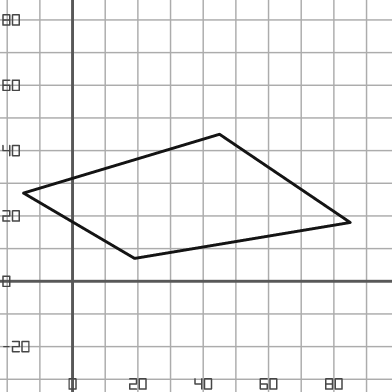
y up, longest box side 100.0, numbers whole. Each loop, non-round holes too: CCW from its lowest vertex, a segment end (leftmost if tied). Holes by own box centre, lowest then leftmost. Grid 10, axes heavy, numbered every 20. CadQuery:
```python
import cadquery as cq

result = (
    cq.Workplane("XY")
    .moveTo(19.0, 7.0)
    .lineTo(85.0, 18.0)
    .lineTo(45.0, 45.0)
    .lineTo(-15.0, 27.0)
    .close()
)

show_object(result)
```